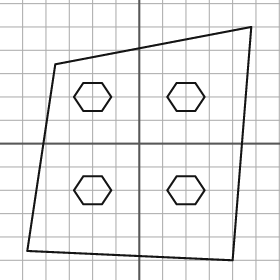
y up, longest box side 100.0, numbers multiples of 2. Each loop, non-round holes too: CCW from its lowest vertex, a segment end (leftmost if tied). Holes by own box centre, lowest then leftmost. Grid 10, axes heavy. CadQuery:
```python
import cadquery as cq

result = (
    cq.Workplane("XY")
    .moveTo(40.0, -50.0)
    .lineTo(48.0, 50.0)
    .lineTo(-36.0, 34.0)
    .lineTo(-48.0, -46.0)
    .close()
    .moveTo(-24.0, -26.0)
    .lineTo(-16.0, -26.0)
    .lineTo(-12.0, -20.0)
    .lineTo(-16.0, -14.0)
    .lineTo(-24.0, -14.0)
    .lineTo(-28.0, -20.0)
    .close()
    .moveTo(16.0, -26.0)
    .lineTo(24.0, -26.0)
    .lineTo(28.0, -20.0)
    .lineTo(24.0, -14.0)
    .lineTo(16.0, -14.0)
    .lineTo(12.0, -20.0)
    .close()
    .moveTo(-24.0, 14.0)
    .lineTo(-16.0, 14.0)
    .lineTo(-12.0, 20.0)
    .lineTo(-16.0, 26.0)
    .lineTo(-24.0, 26.0)
    .lineTo(-28.0, 20.0)
    .close()
    .moveTo(16.0, 14.0)
    .lineTo(24.0, 14.0)
    .lineTo(28.0, 20.0)
    .lineTo(24.0, 26.0)
    .lineTo(16.0, 26.0)
    .lineTo(12.0, 20.0)
    .close()
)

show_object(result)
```